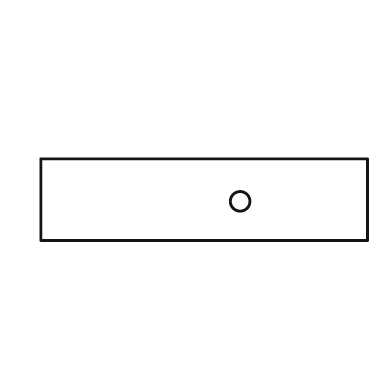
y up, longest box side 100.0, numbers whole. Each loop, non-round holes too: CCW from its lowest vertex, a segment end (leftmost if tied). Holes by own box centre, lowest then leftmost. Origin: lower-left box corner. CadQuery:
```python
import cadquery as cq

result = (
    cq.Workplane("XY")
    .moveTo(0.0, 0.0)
    .lineTo(100.0, 0.0)
    .lineTo(100.0, 25.0)
    .lineTo(0.0, 25.0)
    .close()
    .moveTo(61.0, 12.0)
    .circle(3.0)
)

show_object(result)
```